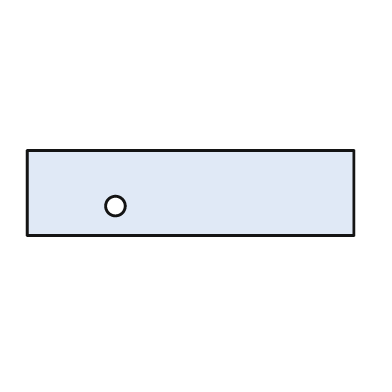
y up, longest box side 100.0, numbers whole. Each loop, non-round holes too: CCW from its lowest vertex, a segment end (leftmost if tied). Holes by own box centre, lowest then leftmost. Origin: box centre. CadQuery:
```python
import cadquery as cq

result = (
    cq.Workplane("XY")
    .moveTo(-50.0, -13.0)
    .lineTo(50.0, -13.0)
    .lineTo(50.0, 13.0)
    .lineTo(-50.0, 13.0)
    .close()
    .moveTo(-23.0, -4.0)
    .circle(3.0)
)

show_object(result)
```